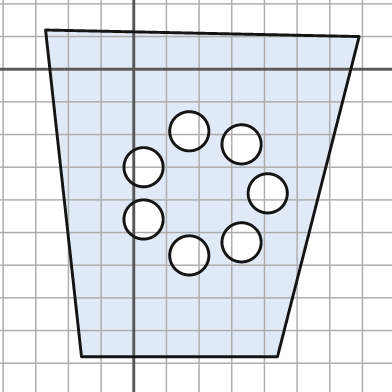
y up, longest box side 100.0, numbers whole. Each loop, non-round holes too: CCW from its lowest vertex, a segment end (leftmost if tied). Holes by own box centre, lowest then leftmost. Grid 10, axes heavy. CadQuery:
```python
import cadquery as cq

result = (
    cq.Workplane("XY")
    .moveTo(-16.0, -88.0)
    .lineTo(44.0, -88.0)
    .lineTo(69.0, 10.0)
    .lineTo(-27.0, 12.0)
    .close()
    .moveTo(17.0, -57.0)
    .circle(6.0)
    .moveTo(33.0, -53.0)
    .circle(6.0)
    .moveTo(3.0, -46.0)
    .circle(6.0)
    .moveTo(41.0, -38.0)
    .circle(6.0)
    .moveTo(3.0, -30.0)
    .circle(6.0)
    .moveTo(33.0, -23.0)
    .circle(6.0)
    .moveTo(17.0, -19.0)
    .circle(6.0)
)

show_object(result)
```